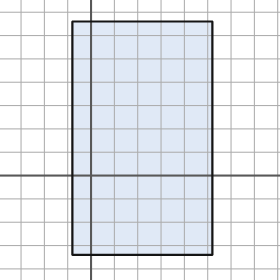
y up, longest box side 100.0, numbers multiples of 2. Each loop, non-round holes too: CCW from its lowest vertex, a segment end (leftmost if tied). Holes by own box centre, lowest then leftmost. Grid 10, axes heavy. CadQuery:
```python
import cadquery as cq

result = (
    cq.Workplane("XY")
    .moveTo(-8.0, -34.0)
    .lineTo(52.0, -34.0)
    .lineTo(52.0, 66.0)
    .lineTo(-8.0, 66.0)
    .close()
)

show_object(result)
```